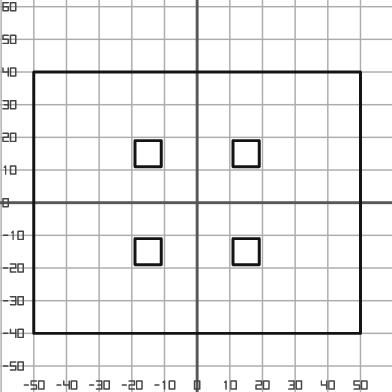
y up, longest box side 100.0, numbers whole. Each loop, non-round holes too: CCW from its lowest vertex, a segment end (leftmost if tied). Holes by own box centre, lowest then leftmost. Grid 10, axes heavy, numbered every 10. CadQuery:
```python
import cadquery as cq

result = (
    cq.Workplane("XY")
    .moveTo(-50.0, -40.0)
    .lineTo(50.0, -40.0)
    .lineTo(50.0, 40.0)
    .lineTo(-50.0, 40.0)
    .close()
    .moveTo(-19.0, -19.0)
    .lineTo(-11.0, -19.0)
    .lineTo(-11.0, -11.0)
    .lineTo(-19.0, -11.0)
    .close()
    .moveTo(11.0, -19.0)
    .lineTo(19.0, -19.0)
    .lineTo(19.0, -11.0)
    .lineTo(11.0, -11.0)
    .close()
    .moveTo(-19.0, 11.0)
    .lineTo(-11.0, 11.0)
    .lineTo(-11.0, 19.0)
    .lineTo(-19.0, 19.0)
    .close()
    .moveTo(11.0, 11.0)
    .lineTo(19.0, 11.0)
    .lineTo(19.0, 19.0)
    .lineTo(11.0, 19.0)
    .close()
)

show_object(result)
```